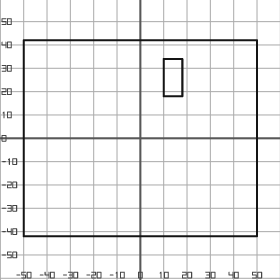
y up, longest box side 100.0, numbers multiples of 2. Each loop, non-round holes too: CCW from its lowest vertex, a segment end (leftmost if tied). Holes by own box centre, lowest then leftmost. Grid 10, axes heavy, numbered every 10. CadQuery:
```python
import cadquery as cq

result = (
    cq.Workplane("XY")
    .moveTo(-50.0, -42.0)
    .lineTo(50.0, -42.0)
    .lineTo(50.0, 42.0)
    .lineTo(-50.0, 42.0)
    .close()
    .moveTo(10.0, 18.0)
    .lineTo(18.0, 18.0)
    .lineTo(18.0, 34.0)
    .lineTo(10.0, 34.0)
    .close()
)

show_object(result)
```